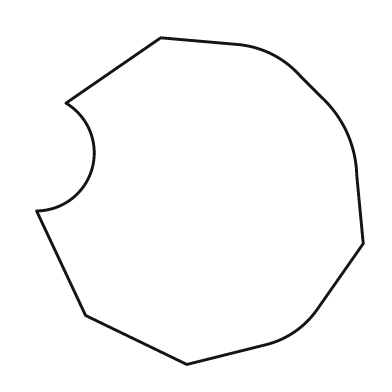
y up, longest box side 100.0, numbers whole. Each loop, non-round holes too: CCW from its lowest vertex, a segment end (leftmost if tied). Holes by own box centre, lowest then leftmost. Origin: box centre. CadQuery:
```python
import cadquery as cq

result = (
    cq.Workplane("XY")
    .moveTo(-4.0, -50.0)
    .lineTo(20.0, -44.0)
    .threePointArc((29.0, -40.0), (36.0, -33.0))
    .lineTo(50.0, -13.0)
    .lineTo(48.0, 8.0)
    .threePointArc((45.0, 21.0), (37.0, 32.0))
    .lineTo(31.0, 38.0)
    .threePointArc((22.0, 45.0), (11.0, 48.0))
    .lineTo(-12.0, 50.0)
    .lineTo(-41.0, 30.0)
    .threePointArc((-33.0, 10.0), (-50.0, -3.0))
    .lineTo(-35.0, -35.0)
    .close()
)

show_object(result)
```